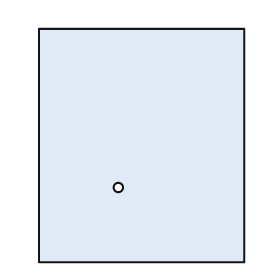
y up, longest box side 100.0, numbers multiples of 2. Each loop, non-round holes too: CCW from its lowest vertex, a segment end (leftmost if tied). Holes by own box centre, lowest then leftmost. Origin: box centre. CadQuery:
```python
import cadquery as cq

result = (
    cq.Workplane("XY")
    .moveTo(-44.0, -50.0)
    .lineTo(44.0, -50.0)
    .lineTo(44.0, 50.0)
    .lineTo(-44.0, 50.0)
    .close()
    .moveTo(-10.0, -18.0)
    .circle(2.0)
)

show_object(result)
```